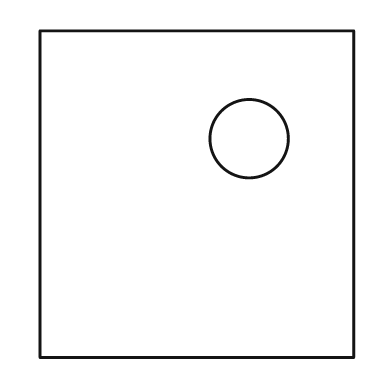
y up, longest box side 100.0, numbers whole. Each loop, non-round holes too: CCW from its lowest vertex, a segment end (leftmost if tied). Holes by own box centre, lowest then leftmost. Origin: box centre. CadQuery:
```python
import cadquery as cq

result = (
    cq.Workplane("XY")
    .moveTo(-48.0, -50.0)
    .lineTo(48.0, -50.0)
    .lineTo(48.0, 50.0)
    .lineTo(-48.0, 50.0)
    .close()
    .moveTo(16.0, 17.0)
    .circle(12.0)
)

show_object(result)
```